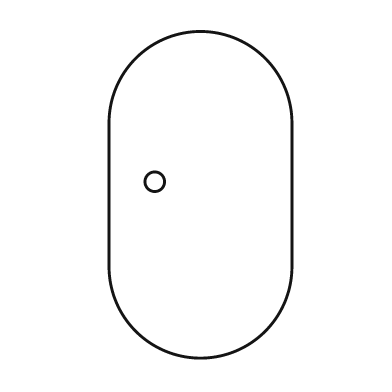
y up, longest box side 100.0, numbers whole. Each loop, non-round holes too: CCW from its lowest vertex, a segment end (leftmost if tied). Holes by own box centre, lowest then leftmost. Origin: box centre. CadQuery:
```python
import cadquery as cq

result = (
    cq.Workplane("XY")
    .moveTo(-28.0, -22.0)
    .threePointArc((0.0, -50.0), (28.0, -22.0))
    .lineTo(28.0, 22.0)
    .threePointArc((0.0, 50.0), (-28.0, 22.0))
    .close()
    .moveTo(-14.0, 4.0)
    .circle(3.0)
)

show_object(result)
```